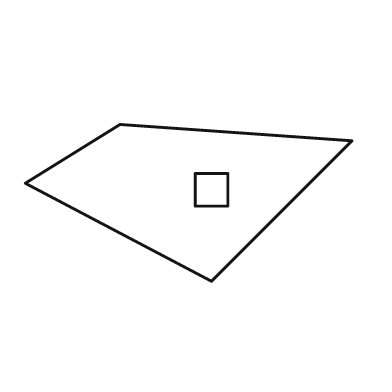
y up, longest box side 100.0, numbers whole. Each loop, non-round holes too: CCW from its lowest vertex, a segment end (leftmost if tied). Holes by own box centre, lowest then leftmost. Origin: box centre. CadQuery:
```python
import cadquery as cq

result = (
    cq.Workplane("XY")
    .moveTo(7.0, -24.0)
    .lineTo(50.0, 19.0)
    .lineTo(-21.0, 24.0)
    .lineTo(-50.0, 6.0)
    .close()
    .moveTo(2.0, -1.0)
    .lineTo(12.0, -1.0)
    .lineTo(12.0, 9.0)
    .lineTo(2.0, 9.0)
    .close()
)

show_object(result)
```